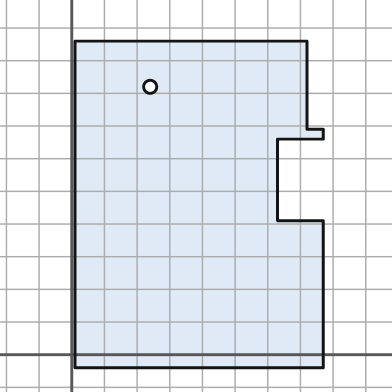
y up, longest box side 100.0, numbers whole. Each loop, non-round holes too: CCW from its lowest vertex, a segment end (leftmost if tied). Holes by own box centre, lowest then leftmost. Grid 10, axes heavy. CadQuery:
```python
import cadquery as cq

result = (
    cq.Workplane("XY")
    .moveTo(1.0, -4.0)
    .lineTo(77.0, -4.0)
    .lineTo(77.0, 41.0)
    .lineTo(63.0, 41.0)
    .lineTo(63.0, 66.0)
    .lineTo(77.0, 66.0)
    .lineTo(77.0, 69.0)
    .lineTo(72.0, 69.0)
    .lineTo(72.0, 96.0)
    .lineTo(1.0, 96.0)
    .close()
    .moveTo(24.0, 82.0)
    .circle(2.0)
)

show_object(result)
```